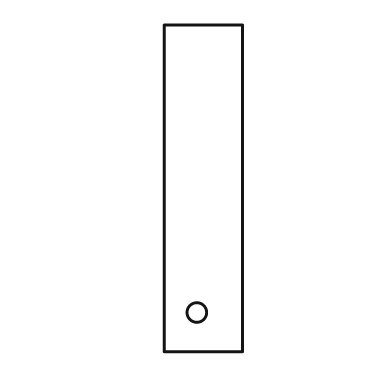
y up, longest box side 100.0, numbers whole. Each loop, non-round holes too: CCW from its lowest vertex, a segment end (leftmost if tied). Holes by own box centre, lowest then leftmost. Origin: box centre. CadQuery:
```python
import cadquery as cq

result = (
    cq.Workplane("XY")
    .moveTo(-12.0, -50.0)
    .lineTo(12.0, -50.0)
    .lineTo(12.0, 50.0)
    .lineTo(-12.0, 50.0)
    .close()
    .moveTo(-2.0, -38.0)
    .circle(3.0)
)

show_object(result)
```